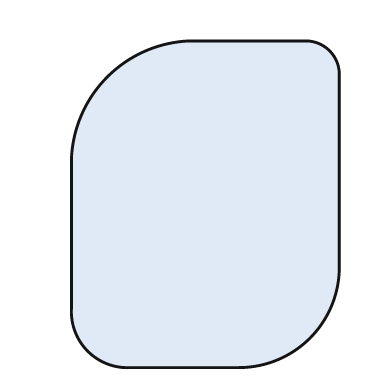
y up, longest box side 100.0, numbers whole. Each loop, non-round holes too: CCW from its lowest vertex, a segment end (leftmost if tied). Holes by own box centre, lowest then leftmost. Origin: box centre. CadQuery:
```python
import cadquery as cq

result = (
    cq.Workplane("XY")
    .moveTo(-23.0, -50.0)
    .lineTo(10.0, -50.0)
    .threePointArc((32.0, -41.0), (41.0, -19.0))
    .lineTo(41.0, 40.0)
    .threePointArc((38.0, 47.0), (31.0, 50.0))
    .lineTo(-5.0, 50.0)
    .threePointArc((-30.0, 39.0), (-41.0, 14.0))
    .lineTo(-41.0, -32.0)
    .threePointArc((-36.0, -45.0), (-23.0, -50.0))
    .close()
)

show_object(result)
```